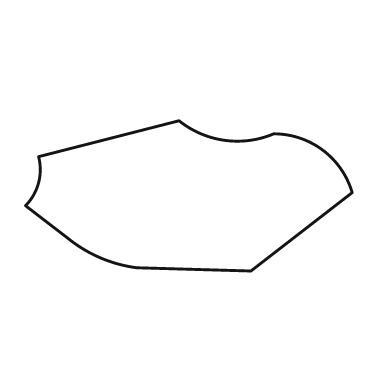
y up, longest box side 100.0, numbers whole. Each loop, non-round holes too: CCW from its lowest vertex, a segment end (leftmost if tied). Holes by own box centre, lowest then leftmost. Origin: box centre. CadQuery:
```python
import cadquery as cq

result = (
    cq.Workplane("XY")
    .moveTo(19.0, -23.0)
    .lineTo(50.0, 1.0)
    .threePointArc((41.0, 14.0), (26.0, 19.0))
    .threePointArc((11.0, 17.0), (-3.0, 23.0))
    .lineTo(-46.0, 12.0)
    .threePointArc((-46.0, 4.0), (-50.0, -3.0))
    .lineTo(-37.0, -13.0)
    .threePointArc((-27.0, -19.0), (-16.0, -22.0))
    .close()
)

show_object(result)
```